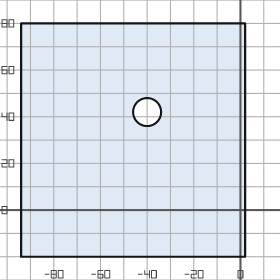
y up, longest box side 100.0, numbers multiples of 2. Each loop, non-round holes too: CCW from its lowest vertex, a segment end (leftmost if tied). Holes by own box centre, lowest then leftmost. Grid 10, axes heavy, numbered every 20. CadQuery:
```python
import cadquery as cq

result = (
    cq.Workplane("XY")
    .moveTo(-94.0, -20.0)
    .lineTo(2.0, -20.0)
    .lineTo(2.0, 80.0)
    .lineTo(-94.0, 80.0)
    .close()
    .moveTo(-40.0, 42.0)
    .circle(6.0)
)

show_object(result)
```